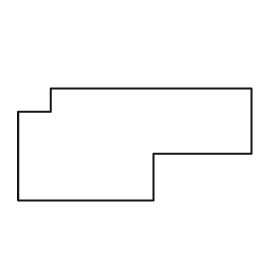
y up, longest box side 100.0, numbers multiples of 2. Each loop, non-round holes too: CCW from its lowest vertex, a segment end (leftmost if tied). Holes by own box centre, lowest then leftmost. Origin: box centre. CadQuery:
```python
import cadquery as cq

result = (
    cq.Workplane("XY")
    .moveTo(-50.0, -24.0)
    .lineTo(8.0, -24.0)
    .lineTo(8.0, -4.0)
    .lineTo(50.0, -4.0)
    .lineTo(50.0, 24.0)
    .lineTo(-36.0, 24.0)
    .lineTo(-36.0, 14.0)
    .lineTo(-50.0, 14.0)
    .close()
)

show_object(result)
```